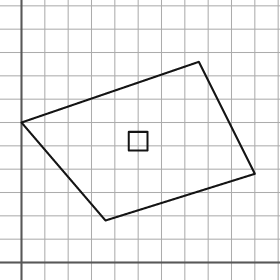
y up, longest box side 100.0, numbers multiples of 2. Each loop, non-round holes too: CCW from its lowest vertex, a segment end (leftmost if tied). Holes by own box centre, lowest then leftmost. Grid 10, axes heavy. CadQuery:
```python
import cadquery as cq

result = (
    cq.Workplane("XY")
    .moveTo(36.0, 18.0)
    .lineTo(100.0, 38.0)
    .lineTo(76.0, 86.0)
    .lineTo(0.0, 60.0)
    .close()
    .moveTo(46.0, 48.0)
    .lineTo(54.0, 48.0)
    .lineTo(54.0, 56.0)
    .lineTo(46.0, 56.0)
    .close()
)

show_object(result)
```